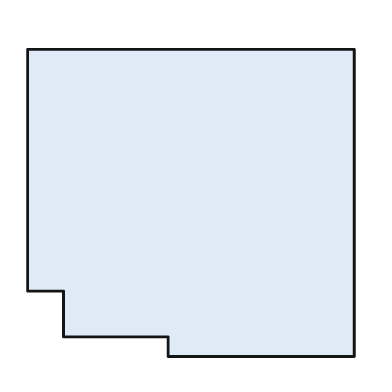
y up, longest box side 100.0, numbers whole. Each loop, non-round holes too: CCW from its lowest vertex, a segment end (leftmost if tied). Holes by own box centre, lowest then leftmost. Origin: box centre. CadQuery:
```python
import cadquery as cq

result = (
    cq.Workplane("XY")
    .moveTo(-7.0, -47.0)
    .lineTo(50.0, -47.0)
    .lineTo(50.0, 47.0)
    .lineTo(-50.0, 47.0)
    .lineTo(-50.0, -27.0)
    .lineTo(-39.0, -27.0)
    .lineTo(-39.0, -41.0)
    .lineTo(-7.0, -41.0)
    .close()
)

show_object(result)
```